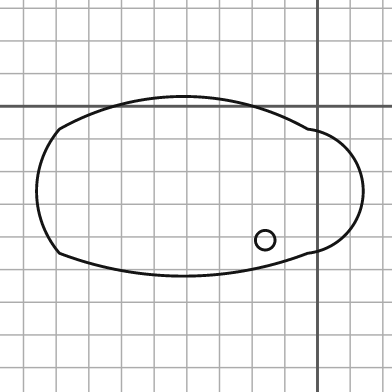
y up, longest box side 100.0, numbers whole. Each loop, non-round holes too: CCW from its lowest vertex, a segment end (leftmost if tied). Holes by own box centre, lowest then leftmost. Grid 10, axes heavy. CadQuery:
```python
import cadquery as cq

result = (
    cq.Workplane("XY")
    .moveTo(-79.0, -45.0)
    .threePointArc((-41.0, -52.0), (-3.0, -45.0))
    .threePointArc((14.0, -26.0), (-3.0, -7.0))
    .threePointArc((-41.0, 3.0), (-79.0, -7.0))
    .threePointArc((-86.0, -26.0), (-79.0, -45.0))
    .close()
    .moveTo(-16.0, -41.0)
    .circle(3.0)
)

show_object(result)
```